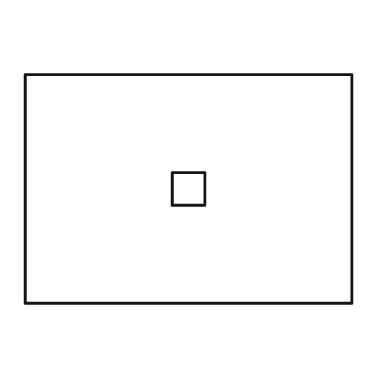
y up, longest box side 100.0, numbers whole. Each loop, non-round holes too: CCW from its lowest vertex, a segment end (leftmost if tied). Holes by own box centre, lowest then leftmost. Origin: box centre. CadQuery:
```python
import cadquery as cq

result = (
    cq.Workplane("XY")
    .moveTo(-50.0, -35.0)
    .lineTo(50.0, -35.0)
    .lineTo(50.0, 35.0)
    .lineTo(-50.0, 35.0)
    .close()
    .moveTo(-5.0, -5.0)
    .lineTo(5.0, -5.0)
    .lineTo(5.0, 5.0)
    .lineTo(-5.0, 5.0)
    .close()
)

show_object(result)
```